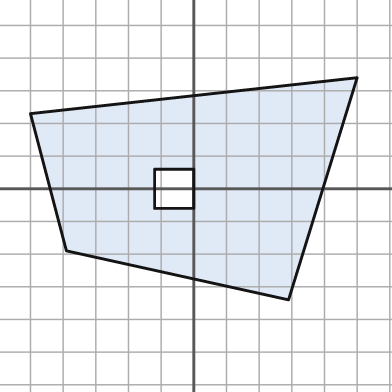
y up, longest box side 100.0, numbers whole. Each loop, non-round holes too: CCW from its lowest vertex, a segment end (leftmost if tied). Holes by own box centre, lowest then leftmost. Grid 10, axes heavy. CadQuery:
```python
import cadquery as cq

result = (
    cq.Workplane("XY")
    .moveTo(29.0, -34.0)
    .lineTo(50.0, 34.0)
    .lineTo(-50.0, 23.0)
    .lineTo(-39.0, -19.0)
    .close()
    .moveTo(-12.0, -6.0)
    .lineTo(0.0, -6.0)
    .lineTo(0.0, 6.0)
    .lineTo(-12.0, 6.0)
    .close()
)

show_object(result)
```